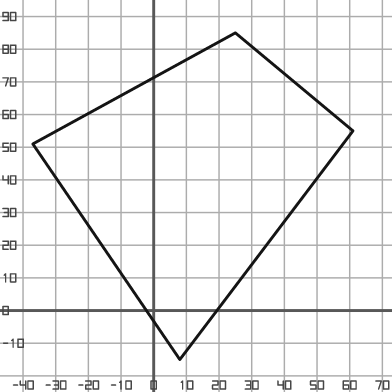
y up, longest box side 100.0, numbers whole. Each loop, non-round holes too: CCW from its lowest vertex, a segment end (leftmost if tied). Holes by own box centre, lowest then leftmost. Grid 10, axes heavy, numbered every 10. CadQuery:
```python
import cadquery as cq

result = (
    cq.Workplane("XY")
    .moveTo(8.0, -15.0)
    .lineTo(61.0, 55.0)
    .lineTo(25.0, 85.0)
    .lineTo(-37.0, 51.0)
    .close()
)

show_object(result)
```